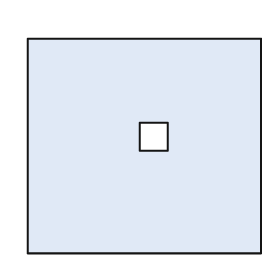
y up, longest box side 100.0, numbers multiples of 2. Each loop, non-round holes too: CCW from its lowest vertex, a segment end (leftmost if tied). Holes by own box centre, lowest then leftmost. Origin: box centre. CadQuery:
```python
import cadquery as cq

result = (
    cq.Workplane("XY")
    .moveTo(-50.0, -46.0)
    .lineTo(50.0, -46.0)
    .lineTo(50.0, 46.0)
    .lineTo(-50.0, 46.0)
    .close()
    .moveTo(-2.0, -2.0)
    .lineTo(10.0, -2.0)
    .lineTo(10.0, 10.0)
    .lineTo(-2.0, 10.0)
    .close()
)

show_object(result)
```